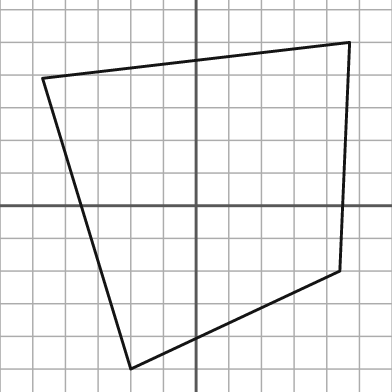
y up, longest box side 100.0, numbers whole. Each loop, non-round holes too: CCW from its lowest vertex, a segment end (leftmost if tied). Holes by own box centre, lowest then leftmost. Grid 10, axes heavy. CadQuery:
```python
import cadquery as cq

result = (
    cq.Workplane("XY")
    .moveTo(-20.0, -50.0)
    .lineTo(44.0, -20.0)
    .lineTo(47.0, 50.0)
    .lineTo(-47.0, 39.0)
    .close()
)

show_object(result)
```